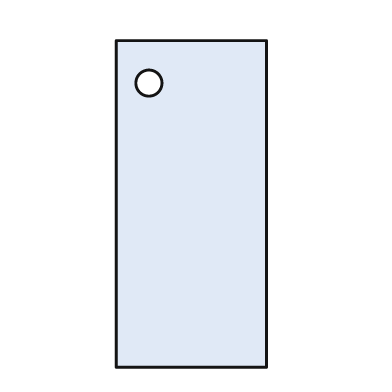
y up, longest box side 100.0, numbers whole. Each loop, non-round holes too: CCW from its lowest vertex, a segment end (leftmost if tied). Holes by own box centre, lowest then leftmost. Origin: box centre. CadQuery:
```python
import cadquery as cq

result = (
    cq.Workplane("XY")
    .moveTo(-23.0, -50.0)
    .lineTo(23.0, -50.0)
    .lineTo(23.0, 50.0)
    .lineTo(-23.0, 50.0)
    .close()
    .moveTo(-13.0, 37.0)
    .circle(4.0)
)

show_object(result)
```